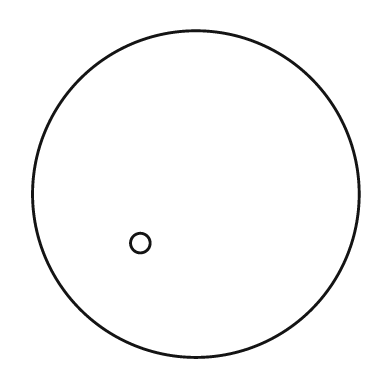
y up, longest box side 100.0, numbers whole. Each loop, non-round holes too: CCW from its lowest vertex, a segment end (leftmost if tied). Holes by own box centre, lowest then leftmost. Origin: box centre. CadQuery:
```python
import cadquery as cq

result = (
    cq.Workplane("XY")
    .moveTo(0.0, 0.0)
    .circle(50.0)
    .moveTo(-17.0, -15.0)
    .circle(3.0)
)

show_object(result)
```